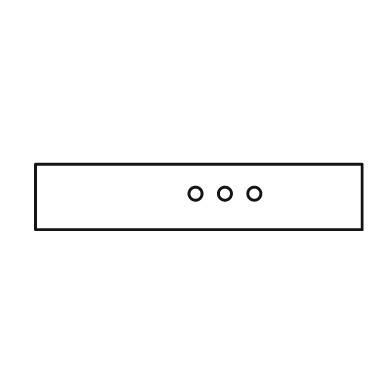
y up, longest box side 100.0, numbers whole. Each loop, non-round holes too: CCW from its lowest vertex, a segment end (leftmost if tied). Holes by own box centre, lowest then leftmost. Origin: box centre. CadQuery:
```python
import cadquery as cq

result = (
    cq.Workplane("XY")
    .moveTo(-50.0, -10.0)
    .lineTo(50.0, -10.0)
    .lineTo(50.0, 10.0)
    .lineTo(-50.0, 10.0)
    .close()
    .moveTo(-1.0, 1.0)
    .circle(2.0)
    .moveTo(8.0, 1.0)
    .circle(2.0)
    .moveTo(17.0, 1.0)
    .circle(2.0)
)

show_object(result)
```